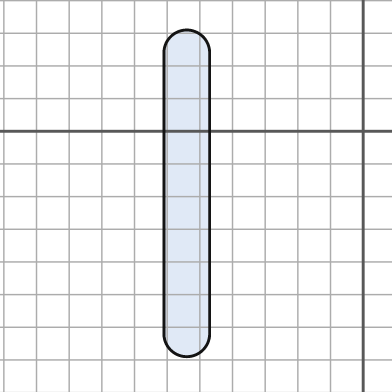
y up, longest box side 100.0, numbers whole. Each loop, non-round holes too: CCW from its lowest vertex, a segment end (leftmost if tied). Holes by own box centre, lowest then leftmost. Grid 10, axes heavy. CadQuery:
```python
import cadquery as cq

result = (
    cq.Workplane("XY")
    .moveTo(-61.0, -62.0)
    .threePointArc((-54.0, -69.0), (-47.0, -62.0))
    .lineTo(-47.0, 24.0)
    .threePointArc((-54.0, 31.0), (-61.0, 24.0))
    .close()
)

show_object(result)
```